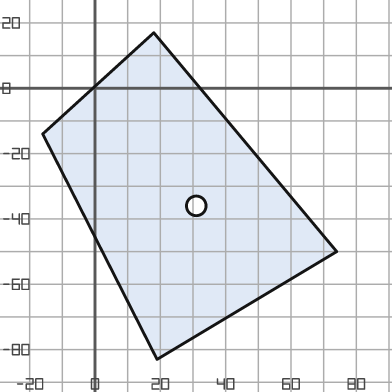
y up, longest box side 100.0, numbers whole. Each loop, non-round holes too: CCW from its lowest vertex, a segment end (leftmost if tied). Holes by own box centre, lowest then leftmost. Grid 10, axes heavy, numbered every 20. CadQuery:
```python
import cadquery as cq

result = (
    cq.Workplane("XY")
    .moveTo(19.0, -83.0)
    .lineTo(74.0, -50.0)
    .lineTo(18.0, 17.0)
    .lineTo(-16.0, -14.0)
    .close()
    .moveTo(31.0, -36.0)
    .circle(3.0)
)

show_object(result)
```